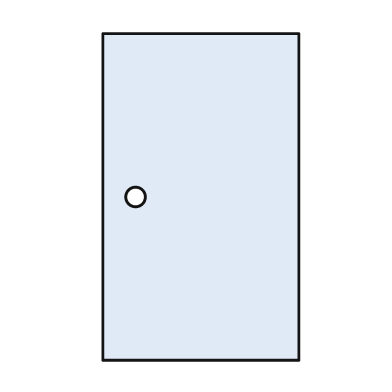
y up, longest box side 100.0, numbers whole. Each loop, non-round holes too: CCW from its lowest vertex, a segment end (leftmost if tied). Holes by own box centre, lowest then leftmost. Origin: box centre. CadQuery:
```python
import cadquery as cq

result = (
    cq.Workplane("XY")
    .moveTo(-30.0, -50.0)
    .lineTo(30.0, -50.0)
    .lineTo(30.0, 50.0)
    .lineTo(-30.0, 50.0)
    .close()
    .moveTo(-20.0, 0.0)
    .circle(3.0)
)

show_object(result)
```